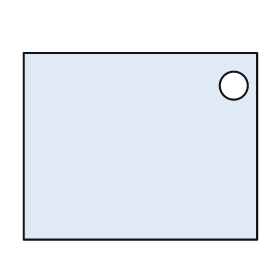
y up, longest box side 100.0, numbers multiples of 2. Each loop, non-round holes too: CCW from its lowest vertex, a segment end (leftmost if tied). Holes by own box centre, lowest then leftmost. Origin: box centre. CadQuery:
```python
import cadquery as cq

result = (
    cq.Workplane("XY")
    .moveTo(-50.0, -40.0)
    .lineTo(50.0, -40.0)
    .lineTo(50.0, 40.0)
    .lineTo(-50.0, 40.0)
    .close()
    .moveTo(40.0, 26.0)
    .circle(6.0)
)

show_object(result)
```